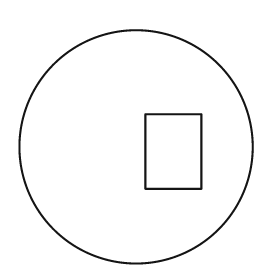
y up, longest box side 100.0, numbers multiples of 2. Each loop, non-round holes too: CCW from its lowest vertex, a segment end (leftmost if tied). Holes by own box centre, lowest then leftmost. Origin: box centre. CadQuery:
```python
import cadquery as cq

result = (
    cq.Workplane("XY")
    .moveTo(0.0, 0.0)
    .circle(50.0)
    .moveTo(4.0, -18.0)
    .lineTo(28.0, -18.0)
    .lineTo(28.0, 14.0)
    .lineTo(4.0, 14.0)
    .close()
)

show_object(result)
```